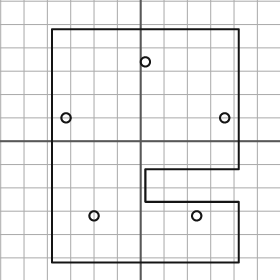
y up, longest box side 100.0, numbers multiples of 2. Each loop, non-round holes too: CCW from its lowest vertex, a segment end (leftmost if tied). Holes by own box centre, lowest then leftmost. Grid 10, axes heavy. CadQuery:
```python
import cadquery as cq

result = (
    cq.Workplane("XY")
    .moveTo(-38.0, -52.0)
    .lineTo(42.0, -52.0)
    .lineTo(42.0, -26.0)
    .lineTo(2.0, -26.0)
    .lineTo(2.0, -12.0)
    .lineTo(42.0, -12.0)
    .lineTo(42.0, 48.0)
    .lineTo(-38.0, 48.0)
    .close()
    .moveTo(-20.0, -32.0)
    .circle(2.0)
    .moveTo(24.0, -32.0)
    .circle(2.0)
    .moveTo(-32.0, 10.0)
    .circle(2.0)
    .moveTo(36.0, 10.0)
    .circle(2.0)
    .moveTo(2.0, 34.0)
    .circle(2.0)
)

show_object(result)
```